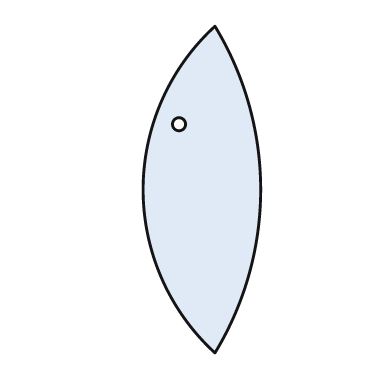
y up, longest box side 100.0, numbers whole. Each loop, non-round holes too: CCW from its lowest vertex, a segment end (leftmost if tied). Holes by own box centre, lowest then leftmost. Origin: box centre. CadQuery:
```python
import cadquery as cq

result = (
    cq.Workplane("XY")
    .moveTo(4.0, -50.0)
    .threePointArc((18.0, 0.0), (4.0, 50.0))
    .threePointArc((-18.0, 0.0), (4.0, -50.0))
    .close()
    .moveTo(-7.0, 20.0)
    .circle(2.0)
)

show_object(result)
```